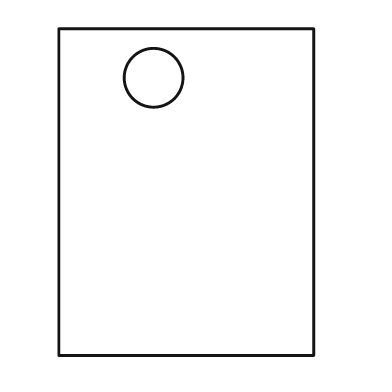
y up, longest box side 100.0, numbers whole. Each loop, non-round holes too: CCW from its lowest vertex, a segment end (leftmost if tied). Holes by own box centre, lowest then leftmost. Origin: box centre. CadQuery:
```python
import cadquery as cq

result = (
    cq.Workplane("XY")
    .moveTo(-39.0, -50.0)
    .lineTo(39.0, -50.0)
    .lineTo(39.0, 50.0)
    .lineTo(-39.0, 50.0)
    .close()
    .moveTo(-10.0, 35.0)
    .circle(9.0)
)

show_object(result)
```